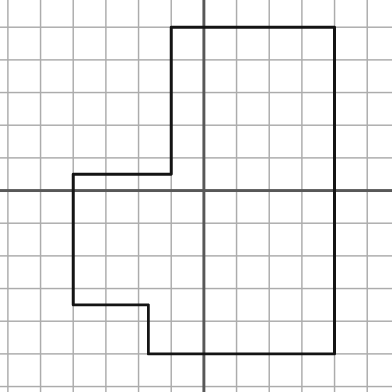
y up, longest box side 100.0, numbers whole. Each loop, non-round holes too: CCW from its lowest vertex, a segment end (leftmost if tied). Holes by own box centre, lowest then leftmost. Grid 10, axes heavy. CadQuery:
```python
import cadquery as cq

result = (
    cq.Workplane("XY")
    .moveTo(-17.0, -50.0)
    .lineTo(40.0, -50.0)
    .lineTo(40.0, 50.0)
    .lineTo(-10.0, 50.0)
    .lineTo(-10.0, 5.0)
    .lineTo(-40.0, 5.0)
    .lineTo(-40.0, -35.0)
    .lineTo(-17.0, -35.0)
    .close()
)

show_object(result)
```